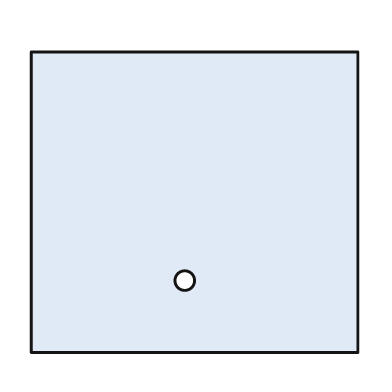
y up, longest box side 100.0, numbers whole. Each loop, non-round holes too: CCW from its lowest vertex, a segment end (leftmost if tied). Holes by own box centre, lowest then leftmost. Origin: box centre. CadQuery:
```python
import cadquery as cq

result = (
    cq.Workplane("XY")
    .moveTo(-50.0, -46.0)
    .lineTo(50.0, -46.0)
    .lineTo(50.0, 46.0)
    .lineTo(-50.0, 46.0)
    .close()
    .moveTo(-3.0, -24.0)
    .circle(3.0)
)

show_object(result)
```